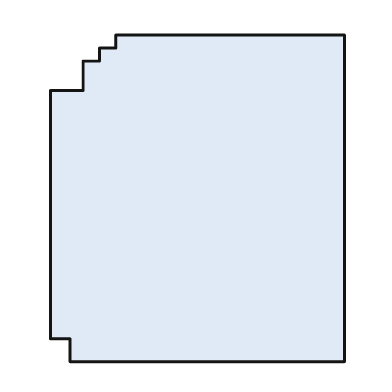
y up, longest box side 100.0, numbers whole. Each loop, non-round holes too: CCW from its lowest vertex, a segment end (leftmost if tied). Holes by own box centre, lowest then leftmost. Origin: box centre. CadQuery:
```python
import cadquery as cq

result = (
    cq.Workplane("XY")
    .moveTo(-39.0, -50.0)
    .lineTo(45.0, -50.0)
    .lineTo(45.0, 50.0)
    .lineTo(-25.0, 50.0)
    .lineTo(-25.0, 46.0)
    .lineTo(-30.0, 46.0)
    .lineTo(-30.0, 42.0)
    .lineTo(-35.0, 42.0)
    .lineTo(-35.0, 33.0)
    .lineTo(-45.0, 33.0)
    .lineTo(-45.0, -43.0)
    .lineTo(-39.0, -43.0)
    .close()
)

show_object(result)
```